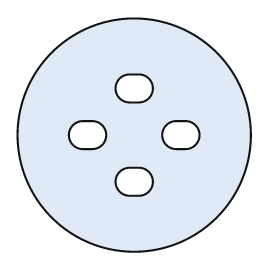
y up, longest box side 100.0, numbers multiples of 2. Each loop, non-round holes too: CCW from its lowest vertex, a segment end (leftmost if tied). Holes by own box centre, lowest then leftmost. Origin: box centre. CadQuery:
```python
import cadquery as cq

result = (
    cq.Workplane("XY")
    .moveTo(0.0, 0.0)
    .circle(50.0)
    .moveTo(-2.0, -26.0)
    .lineTo(2.0, -26.0)
    .threePointArc((8.0, -20.0), (2.0, -14.0))
    .lineTo(-2.0, -14.0)
    .threePointArc((-8.0, -20.0), (-2.0, -26.0))
    .close()
    .moveTo(-22.0, -6.0)
    .lineTo(-18.0, -6.0)
    .threePointArc((-12.0, 0.0), (-18.0, 6.0))
    .lineTo(-22.0, 6.0)
    .threePointArc((-28.0, 0.0), (-22.0, -6.0))
    .close()
    .moveTo(18.0, -6.0)
    .lineTo(22.0, -6.0)
    .threePointArc((28.0, 0.0), (22.0, 6.0))
    .lineTo(18.0, 6.0)
    .threePointArc((12.0, 0.0), (18.0, -6.0))
    .close()
    .moveTo(-2.0, 14.0)
    .lineTo(2.0, 14.0)
    .threePointArc((8.0, 20.0), (2.0, 26.0))
    .lineTo(-2.0, 26.0)
    .threePointArc((-8.0, 20.0), (-2.0, 14.0))
    .close()
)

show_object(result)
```